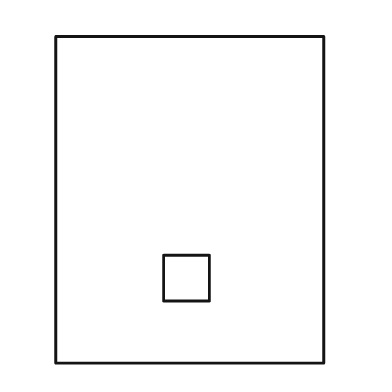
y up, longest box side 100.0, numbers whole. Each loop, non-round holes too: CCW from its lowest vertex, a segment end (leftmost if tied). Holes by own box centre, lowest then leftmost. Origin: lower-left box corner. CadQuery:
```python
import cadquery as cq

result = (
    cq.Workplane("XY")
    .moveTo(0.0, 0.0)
    .lineTo(82.0, 0.0)
    .lineTo(82.0, 100.0)
    .lineTo(0.0, 100.0)
    .close()
    .moveTo(33.0, 19.0)
    .lineTo(47.0, 19.0)
    .lineTo(47.0, 33.0)
    .lineTo(33.0, 33.0)
    .close()
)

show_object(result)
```